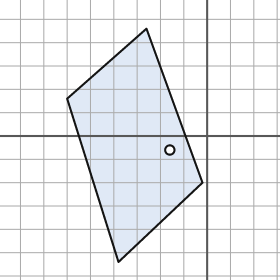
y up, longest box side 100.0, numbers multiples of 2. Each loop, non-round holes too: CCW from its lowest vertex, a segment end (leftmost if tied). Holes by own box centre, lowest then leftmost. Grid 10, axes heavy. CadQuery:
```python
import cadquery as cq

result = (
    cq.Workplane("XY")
    .moveTo(-38.0, -54.0)
    .lineTo(-2.0, -20.0)
    .lineTo(-26.0, 46.0)
    .lineTo(-60.0, 16.0)
    .close()
    .moveTo(-16.0, -6.0)
    .circle(2.0)
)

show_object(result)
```